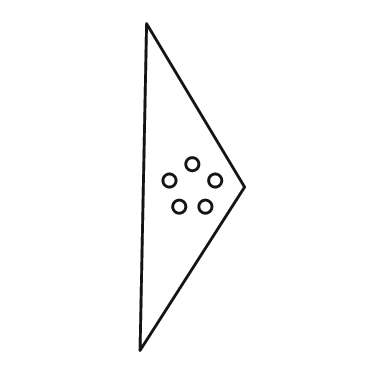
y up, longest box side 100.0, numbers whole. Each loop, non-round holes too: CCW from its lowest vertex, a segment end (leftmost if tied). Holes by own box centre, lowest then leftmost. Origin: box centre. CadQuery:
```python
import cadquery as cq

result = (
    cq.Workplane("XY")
    .moveTo(-16.0, -50.0)
    .lineTo(16.0, 0.0)
    .lineTo(-14.0, 50.0)
    .close()
    .moveTo(-4.0, -6.0)
    .circle(2.0)
    .moveTo(4.0, -6.0)
    .circle(2.0)
    .moveTo(-7.0, 2.0)
    .circle(2.0)
    .moveTo(7.0, 2.0)
    .circle(2.0)
    .moveTo(0.0, 7.0)
    .circle(2.0)
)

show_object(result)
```